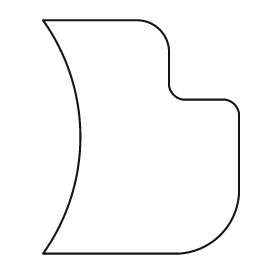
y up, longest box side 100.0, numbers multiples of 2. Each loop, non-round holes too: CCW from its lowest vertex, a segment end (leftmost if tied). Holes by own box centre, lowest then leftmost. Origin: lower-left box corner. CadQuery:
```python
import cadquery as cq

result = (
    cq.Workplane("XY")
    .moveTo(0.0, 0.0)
    .lineTo(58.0, 0.0)
    .threePointArc((76.0, 8.0), (84.0, 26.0))
    .lineTo(84.0, 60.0)
    .threePointArc((82.0, 64.0), (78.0, 66.0))
    .lineTo(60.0, 66.0)
    .threePointArc((56.0, 68.0), (54.0, 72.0))
    .lineTo(54.0, 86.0)
    .threePointArc((50.0, 96.0), (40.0, 100.0))
    .lineTo(0.0, 100.0)
    .threePointArc((16.0, 50.0), (0.0, 0.0))
    .close()
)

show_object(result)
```